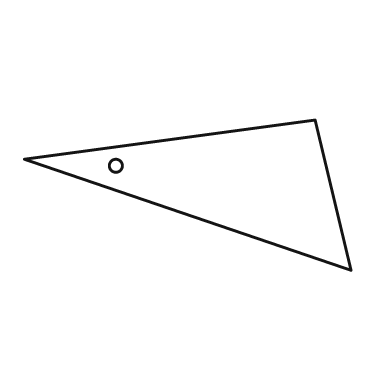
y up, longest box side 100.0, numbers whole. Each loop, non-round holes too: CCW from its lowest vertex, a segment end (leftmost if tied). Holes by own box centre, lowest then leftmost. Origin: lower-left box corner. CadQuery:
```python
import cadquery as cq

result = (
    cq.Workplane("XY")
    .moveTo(100.0, 0.0)
    .lineTo(89.0, 46.0)
    .lineTo(0.0, 34.0)
    .close()
    .moveTo(28.0, 32.0)
    .circle(2.0)
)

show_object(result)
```